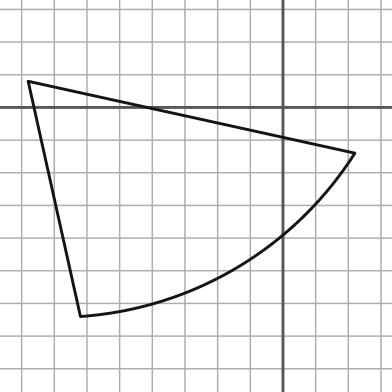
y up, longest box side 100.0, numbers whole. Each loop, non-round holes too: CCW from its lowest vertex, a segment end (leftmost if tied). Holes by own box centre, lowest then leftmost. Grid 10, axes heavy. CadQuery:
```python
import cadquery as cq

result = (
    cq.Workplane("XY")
    .moveTo(-62.0, -64.0)
    .threePointArc((-14.0, -49.0), (22.0, -14.0))
    .lineTo(-78.0, 8.0)
    .close()
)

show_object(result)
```